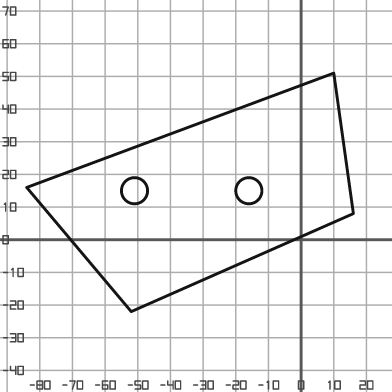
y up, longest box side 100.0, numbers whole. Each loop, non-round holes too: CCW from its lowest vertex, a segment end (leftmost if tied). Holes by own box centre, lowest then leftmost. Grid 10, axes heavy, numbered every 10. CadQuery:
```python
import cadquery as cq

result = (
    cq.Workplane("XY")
    .moveTo(-52.0, -22.0)
    .lineTo(16.0, 8.0)
    .lineTo(10.0, 51.0)
    .lineTo(-84.0, 16.0)
    .close()
    .moveTo(-51.0, 15.0)
    .circle(4.0)
    .moveTo(-16.0, 15.0)
    .circle(4.0)
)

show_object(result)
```